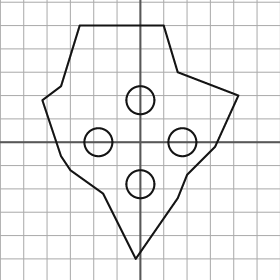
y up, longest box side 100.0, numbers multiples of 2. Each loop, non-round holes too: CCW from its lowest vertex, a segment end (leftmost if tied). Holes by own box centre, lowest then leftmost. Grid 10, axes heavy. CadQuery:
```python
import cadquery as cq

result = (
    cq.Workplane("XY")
    .moveTo(-2.0, -50.0)
    .lineTo(16.0, -24.0)
    .lineTo(20.0, -14.0)
    .lineTo(32.0, -2.0)
    .lineTo(42.0, 20.0)
    .lineTo(16.0, 30.0)
    .lineTo(10.0, 50.0)
    .lineTo(-26.0, 50.0)
    .lineTo(-34.0, 24.0)
    .lineTo(-42.0, 18.0)
    .lineTo(-34.0, -6.0)
    .lineTo(-30.0, -12.0)
    .lineTo(-16.0, -22.0)
    .close()
    .moveTo(0.0, -18.0)
    .circle(6.0)
    .moveTo(-18.0, 0.0)
    .circle(6.0)
    .moveTo(18.0, 0.0)
    .circle(6.0)
    .moveTo(0.0, 18.0)
    .circle(6.0)
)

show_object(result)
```